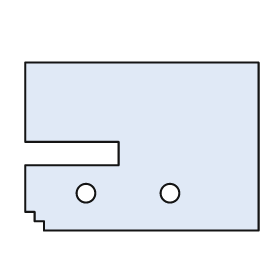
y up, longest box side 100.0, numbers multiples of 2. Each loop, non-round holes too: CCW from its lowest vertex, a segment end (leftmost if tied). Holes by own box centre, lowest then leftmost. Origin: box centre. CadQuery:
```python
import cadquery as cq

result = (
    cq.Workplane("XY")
    .moveTo(-42.0, -36.0)
    .lineTo(50.0, -36.0)
    .lineTo(50.0, 36.0)
    .lineTo(-50.0, 36.0)
    .lineTo(-50.0, 2.0)
    .lineTo(-10.0, 2.0)
    .lineTo(-10.0, -8.0)
    .lineTo(-50.0, -8.0)
    .lineTo(-50.0, -28.0)
    .lineTo(-46.0, -28.0)
    .lineTo(-46.0, -32.0)
    .lineTo(-42.0, -32.0)
    .close()
    .moveTo(-24.0, -20.0)
    .circle(4.0)
    .moveTo(12.0, -20.0)
    .circle(4.0)
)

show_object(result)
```